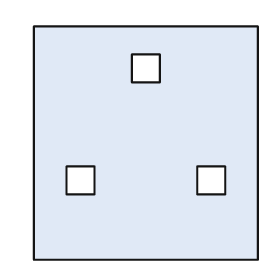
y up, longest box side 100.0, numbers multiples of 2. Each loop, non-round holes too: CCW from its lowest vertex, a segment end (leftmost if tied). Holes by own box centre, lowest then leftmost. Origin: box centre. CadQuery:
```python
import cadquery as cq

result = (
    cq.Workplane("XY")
    .moveTo(-48.0, -50.0)
    .lineTo(48.0, -50.0)
    .lineTo(48.0, 50.0)
    .lineTo(-48.0, 50.0)
    .close()
    .moveTo(-34.0, -22.0)
    .lineTo(-22.0, -22.0)
    .lineTo(-22.0, -10.0)
    .lineTo(-34.0, -10.0)
    .close()
    .moveTo(22.0, -22.0)
    .lineTo(34.0, -22.0)
    .lineTo(34.0, -10.0)
    .lineTo(22.0, -10.0)
    .close()
    .moveTo(-6.0, 26.0)
    .lineTo(6.0, 26.0)
    .lineTo(6.0, 38.0)
    .lineTo(-6.0, 38.0)
    .close()
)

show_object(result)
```